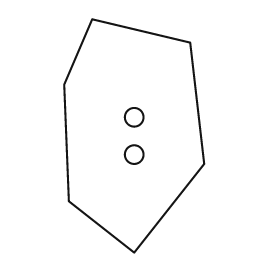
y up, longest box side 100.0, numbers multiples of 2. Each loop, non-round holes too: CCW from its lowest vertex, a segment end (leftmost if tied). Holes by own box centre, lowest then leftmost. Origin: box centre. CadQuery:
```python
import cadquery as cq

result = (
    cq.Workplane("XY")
    .moveTo(0.0, -50.0)
    .lineTo(30.0, -12.0)
    .lineTo(24.0, 40.0)
    .lineTo(-18.0, 50.0)
    .lineTo(-30.0, 22.0)
    .lineTo(-28.0, -28.0)
    .close()
    .moveTo(0.0, -8.0)
    .circle(4.0)
    .moveTo(0.0, 8.0)
    .circle(4.0)
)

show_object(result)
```